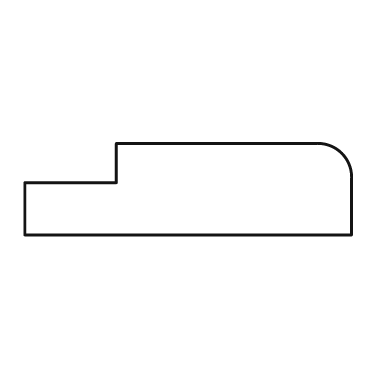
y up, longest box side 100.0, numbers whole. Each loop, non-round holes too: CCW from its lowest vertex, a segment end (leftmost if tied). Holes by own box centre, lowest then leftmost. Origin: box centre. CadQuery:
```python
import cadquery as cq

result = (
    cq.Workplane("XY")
    .moveTo(-50.0, -14.0)
    .lineTo(50.0, -14.0)
    .lineTo(50.0, 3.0)
    .threePointArc((47.0, 11.0), (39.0, 14.0))
    .lineTo(-22.0, 14.0)
    .lineTo(-22.0, 2.0)
    .lineTo(-50.0, 2.0)
    .close()
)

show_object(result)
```